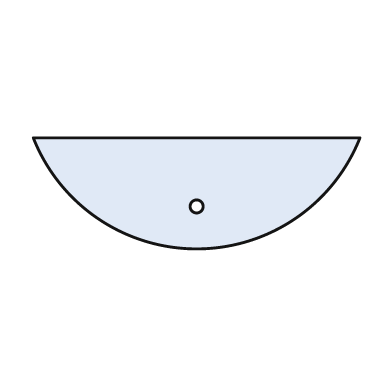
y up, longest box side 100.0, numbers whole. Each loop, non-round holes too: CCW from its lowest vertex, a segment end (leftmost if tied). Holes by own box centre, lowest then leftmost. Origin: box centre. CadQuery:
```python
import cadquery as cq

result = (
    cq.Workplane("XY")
    .moveTo(-50.0, 17.0)
    .threePointArc((0.0, -17.0), (50.0, 17.0))
    .close()
    .moveTo(0.0, -4.0)
    .circle(2.0)
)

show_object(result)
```